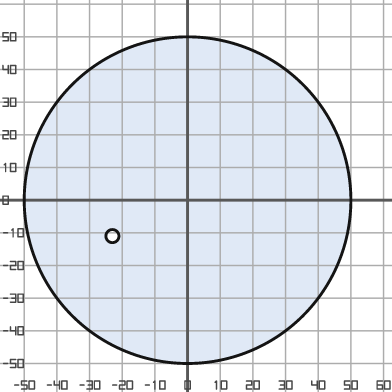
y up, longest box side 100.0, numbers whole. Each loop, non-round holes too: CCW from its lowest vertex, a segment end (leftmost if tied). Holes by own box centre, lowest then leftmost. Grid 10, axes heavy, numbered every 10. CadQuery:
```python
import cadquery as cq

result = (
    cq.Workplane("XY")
    .moveTo(0.0, 0.0)
    .circle(50.0)
    .moveTo(-23.0, -11.0)
    .circle(2.0)
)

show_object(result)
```